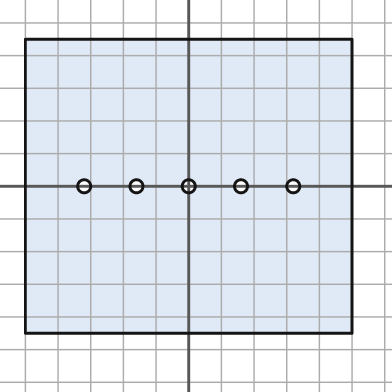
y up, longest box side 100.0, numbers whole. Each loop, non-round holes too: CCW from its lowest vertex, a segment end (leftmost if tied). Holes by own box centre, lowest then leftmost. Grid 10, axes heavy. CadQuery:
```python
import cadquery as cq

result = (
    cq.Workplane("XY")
    .moveTo(-50.0, -45.0)
    .lineTo(50.0, -45.0)
    .lineTo(50.0, 45.0)
    .lineTo(-50.0, 45.0)
    .close()
    .moveTo(-32.0, 0.0)
    .circle(2.0)
    .moveTo(-16.0, 0.0)
    .circle(2.0)
    .moveTo(0.0, 0.0)
    .circle(2.0)
    .moveTo(16.0, 0.0)
    .circle(2.0)
    .moveTo(32.0, 0.0)
    .circle(2.0)
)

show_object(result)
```